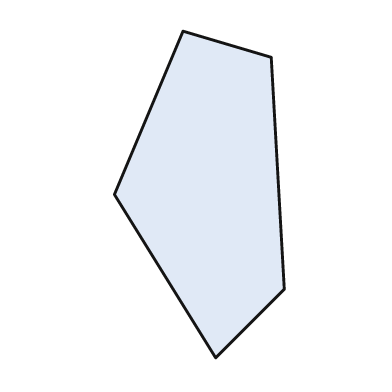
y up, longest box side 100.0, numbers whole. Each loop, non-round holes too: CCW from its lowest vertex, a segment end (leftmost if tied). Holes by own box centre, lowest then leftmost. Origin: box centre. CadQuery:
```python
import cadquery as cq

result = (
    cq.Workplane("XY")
    .moveTo(5.0, -50.0)
    .lineTo(26.0, -29.0)
    .lineTo(22.0, 42.0)
    .lineTo(-5.0, 50.0)
    .lineTo(-26.0, 0.0)
    .close()
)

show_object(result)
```